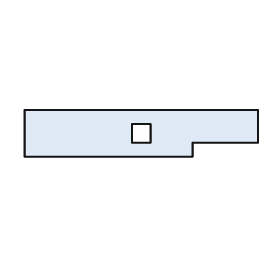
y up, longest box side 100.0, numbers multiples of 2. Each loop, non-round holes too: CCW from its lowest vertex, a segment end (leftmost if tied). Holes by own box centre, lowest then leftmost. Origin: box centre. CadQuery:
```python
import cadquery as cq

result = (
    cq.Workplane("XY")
    .moveTo(-50.0, -10.0)
    .lineTo(22.0, -10.0)
    .lineTo(22.0, -4.0)
    .lineTo(50.0, -4.0)
    .lineTo(50.0, 10.0)
    .lineTo(-50.0, 10.0)
    .close()
    .moveTo(-4.0, -4.0)
    .lineTo(4.0, -4.0)
    .lineTo(4.0, 4.0)
    .lineTo(-4.0, 4.0)
    .close()
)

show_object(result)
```